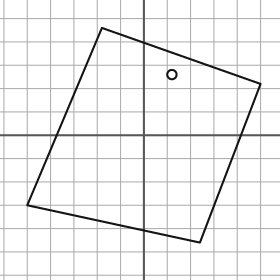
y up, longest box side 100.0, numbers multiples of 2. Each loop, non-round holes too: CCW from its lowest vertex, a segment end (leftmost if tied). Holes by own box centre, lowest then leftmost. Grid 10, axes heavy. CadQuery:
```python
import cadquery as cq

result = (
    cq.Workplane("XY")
    .moveTo(24.0, -46.0)
    .lineTo(50.0, 22.0)
    .lineTo(-18.0, 46.0)
    .lineTo(-50.0, -30.0)
    .close()
    .moveTo(12.0, 26.0)
    .circle(2.0)
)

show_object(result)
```